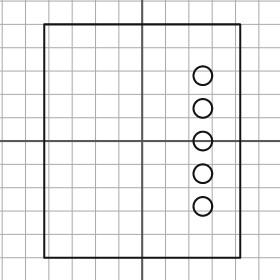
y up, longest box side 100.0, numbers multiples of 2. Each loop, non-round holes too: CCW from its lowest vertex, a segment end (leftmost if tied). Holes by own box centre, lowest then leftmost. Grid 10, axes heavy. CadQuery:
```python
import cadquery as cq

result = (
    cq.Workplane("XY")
    .moveTo(-42.0, -50.0)
    .lineTo(42.0, -50.0)
    .lineTo(42.0, 50.0)
    .lineTo(-42.0, 50.0)
    .close()
    .moveTo(26.0, -28.0)
    .circle(4.0)
    .moveTo(26.0, -14.0)
    .circle(4.0)
    .moveTo(26.0, 0.0)
    .circle(4.0)
    .moveTo(26.0, 14.0)
    .circle(4.0)
    .moveTo(26.0, 28.0)
    .circle(4.0)
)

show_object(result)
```